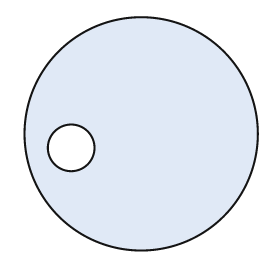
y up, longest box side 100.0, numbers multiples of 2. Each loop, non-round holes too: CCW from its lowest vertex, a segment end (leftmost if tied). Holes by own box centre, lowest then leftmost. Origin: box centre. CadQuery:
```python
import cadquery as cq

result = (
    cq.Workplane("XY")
    .moveTo(0.0, 0.0)
    .circle(50.0)
    .moveTo(-30.0, -6.0)
    .circle(10.0)
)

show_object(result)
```